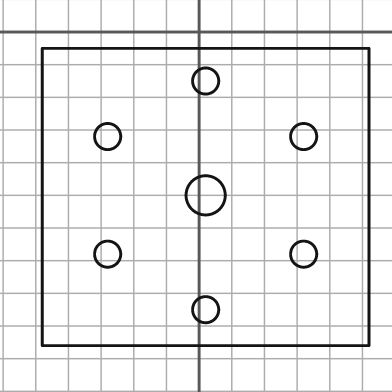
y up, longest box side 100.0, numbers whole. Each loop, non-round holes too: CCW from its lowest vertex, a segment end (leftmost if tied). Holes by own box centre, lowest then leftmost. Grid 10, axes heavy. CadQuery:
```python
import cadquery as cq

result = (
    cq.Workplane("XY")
    .moveTo(-48.0, -96.0)
    .lineTo(52.0, -96.0)
    .lineTo(52.0, -5.0)
    .lineTo(-48.0, -5.0)
    .close()
    .moveTo(2.0, -85.0)
    .circle(4.0)
    .moveTo(-28.0, -68.0)
    .circle(4.0)
    .moveTo(32.0, -68.0)
    .circle(4.0)
    .moveTo(2.0, -50.0)
    .circle(6.0)
    .moveTo(-28.0, -32.0)
    .circle(4.0)
    .moveTo(32.0, -32.0)
    .circle(4.0)
    .moveTo(2.0, -15.0)
    .circle(4.0)
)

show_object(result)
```